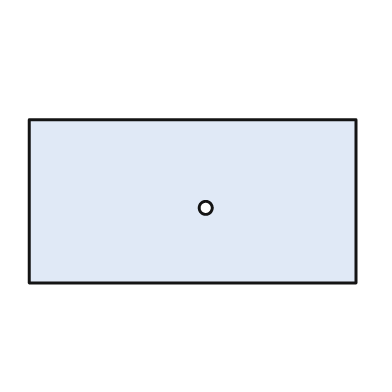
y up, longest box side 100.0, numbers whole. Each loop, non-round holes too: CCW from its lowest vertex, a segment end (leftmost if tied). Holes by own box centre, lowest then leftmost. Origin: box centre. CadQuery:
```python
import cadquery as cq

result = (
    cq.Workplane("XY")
    .moveTo(-50.0, -25.0)
    .lineTo(50.0, -25.0)
    .lineTo(50.0, 25.0)
    .lineTo(-50.0, 25.0)
    .close()
    .moveTo(4.0, -2.0)
    .circle(2.0)
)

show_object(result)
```